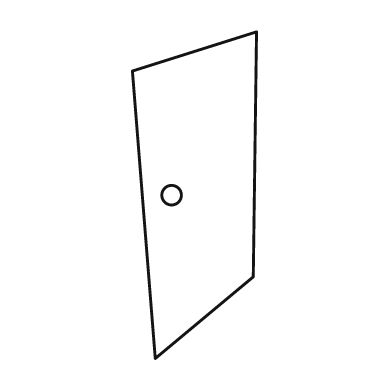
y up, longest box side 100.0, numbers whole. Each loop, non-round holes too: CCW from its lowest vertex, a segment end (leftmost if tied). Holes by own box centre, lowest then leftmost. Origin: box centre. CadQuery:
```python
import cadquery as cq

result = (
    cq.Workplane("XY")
    .moveTo(-12.0, -50.0)
    .lineTo(18.0, -25.0)
    .lineTo(19.0, 50.0)
    .lineTo(-19.0, 38.0)
    .close()
    .moveTo(-7.0, 0.0)
    .circle(3.0)
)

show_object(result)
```